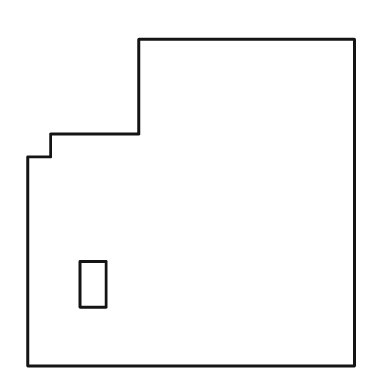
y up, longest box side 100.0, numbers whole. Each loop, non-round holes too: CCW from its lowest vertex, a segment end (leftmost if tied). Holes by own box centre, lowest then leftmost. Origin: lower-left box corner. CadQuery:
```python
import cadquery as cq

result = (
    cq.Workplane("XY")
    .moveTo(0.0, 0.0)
    .lineTo(100.0, 0.0)
    .lineTo(100.0, 100.0)
    .lineTo(34.0, 100.0)
    .lineTo(34.0, 71.0)
    .lineTo(7.0, 71.0)
    .lineTo(7.0, 64.0)
    .lineTo(0.0, 64.0)
    .close()
    .moveTo(16.0, 18.0)
    .lineTo(24.0, 18.0)
    .lineTo(24.0, 32.0)
    .lineTo(16.0, 32.0)
    .close()
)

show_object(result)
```